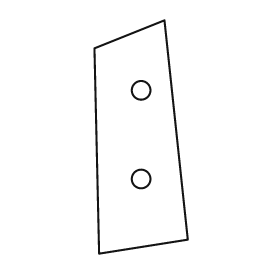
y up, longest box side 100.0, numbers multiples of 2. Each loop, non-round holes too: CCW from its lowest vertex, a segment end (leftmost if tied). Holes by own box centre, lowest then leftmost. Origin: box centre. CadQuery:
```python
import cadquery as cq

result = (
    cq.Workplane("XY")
    .moveTo(-18.0, -50.0)
    .lineTo(20.0, -44.0)
    .lineTo(10.0, 50.0)
    .lineTo(-20.0, 38.0)
    .close()
    .moveTo(0.0, -18.0)
    .circle(4.0)
    .moveTo(0.0, 20.0)
    .circle(4.0)
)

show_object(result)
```